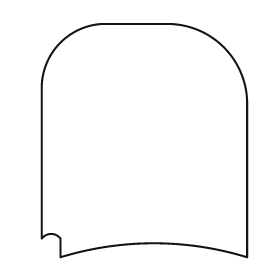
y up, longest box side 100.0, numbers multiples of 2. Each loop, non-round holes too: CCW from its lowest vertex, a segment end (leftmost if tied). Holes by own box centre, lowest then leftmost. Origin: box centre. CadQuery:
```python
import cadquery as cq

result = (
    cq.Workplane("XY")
    .moveTo(-36.0, -50.0)
    .threePointArc((4.0, -44.0), (44.0, -50.0))
    .lineTo(44.0, 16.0)
    .threePointArc((34.0, 40.0), (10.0, 50.0))
    .lineTo(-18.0, 50.0)
    .threePointArc((-36.0, 42.0), (-44.0, 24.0))
    .lineTo(-44.0, -42.0)
    .threePointArc((-40.0, -40.0), (-36.0, -42.0))
    .close()
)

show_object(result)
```